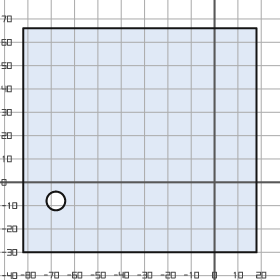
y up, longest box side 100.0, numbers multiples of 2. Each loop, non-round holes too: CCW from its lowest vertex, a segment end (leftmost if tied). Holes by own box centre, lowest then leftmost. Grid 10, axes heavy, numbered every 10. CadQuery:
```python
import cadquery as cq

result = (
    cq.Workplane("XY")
    .moveTo(-82.0, -30.0)
    .lineTo(18.0, -30.0)
    .lineTo(18.0, 66.0)
    .lineTo(-82.0, 66.0)
    .close()
    .moveTo(-68.0, -8.0)
    .circle(4.0)
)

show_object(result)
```